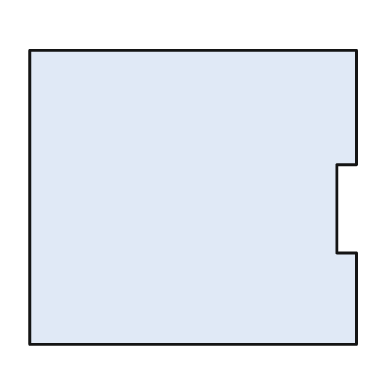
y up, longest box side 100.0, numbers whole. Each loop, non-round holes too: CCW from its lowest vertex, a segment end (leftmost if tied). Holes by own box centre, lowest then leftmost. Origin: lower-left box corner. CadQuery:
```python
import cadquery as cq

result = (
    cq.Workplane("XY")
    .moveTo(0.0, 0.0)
    .lineTo(100.0, 0.0)
    .lineTo(100.0, 28.0)
    .lineTo(94.0, 28.0)
    .lineTo(94.0, 55.0)
    .lineTo(100.0, 55.0)
    .lineTo(100.0, 90.0)
    .lineTo(0.0, 90.0)
    .close()
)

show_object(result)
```